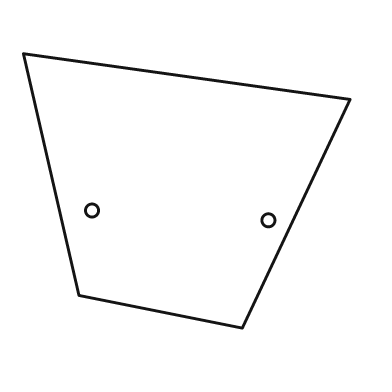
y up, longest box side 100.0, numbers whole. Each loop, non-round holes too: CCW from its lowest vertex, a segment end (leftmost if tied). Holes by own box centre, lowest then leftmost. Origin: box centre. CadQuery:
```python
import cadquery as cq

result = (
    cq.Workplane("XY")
    .moveTo(17.0, -42.0)
    .lineTo(50.0, 28.0)
    .lineTo(-50.0, 42.0)
    .lineTo(-33.0, -32.0)
    .close()
    .moveTo(25.0, -9.0)
    .circle(2.0)
    .moveTo(-29.0, -6.0)
    .circle(2.0)
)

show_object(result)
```